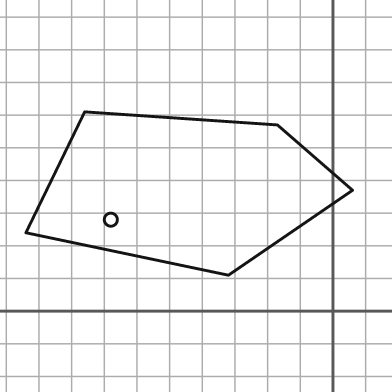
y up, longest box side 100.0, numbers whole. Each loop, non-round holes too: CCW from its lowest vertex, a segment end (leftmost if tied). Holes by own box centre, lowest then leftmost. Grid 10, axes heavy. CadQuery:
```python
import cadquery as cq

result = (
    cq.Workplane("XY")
    .moveTo(-32.0, 11.0)
    .lineTo(6.0, 37.0)
    .lineTo(-17.0, 57.0)
    .lineTo(-76.0, 61.0)
    .lineTo(-94.0, 24.0)
    .close()
    .moveTo(-68.0, 28.0)
    .circle(2.0)
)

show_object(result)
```